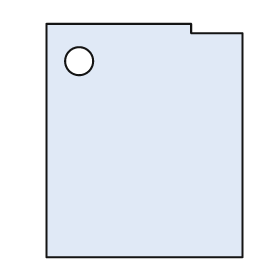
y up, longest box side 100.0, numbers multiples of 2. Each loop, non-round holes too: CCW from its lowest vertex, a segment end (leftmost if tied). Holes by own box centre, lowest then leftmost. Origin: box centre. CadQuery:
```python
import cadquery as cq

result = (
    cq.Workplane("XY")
    .moveTo(-42.0, -50.0)
    .lineTo(42.0, -50.0)
    .lineTo(42.0, 46.0)
    .lineTo(20.0, 46.0)
    .lineTo(20.0, 50.0)
    .lineTo(-42.0, 50.0)
    .close()
    .moveTo(-28.0, 34.0)
    .circle(6.0)
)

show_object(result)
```